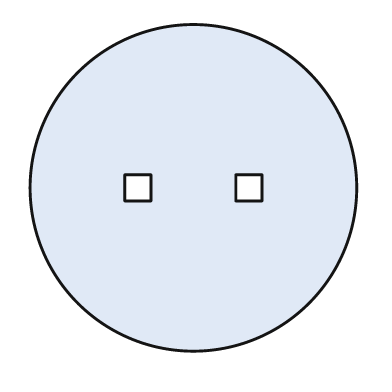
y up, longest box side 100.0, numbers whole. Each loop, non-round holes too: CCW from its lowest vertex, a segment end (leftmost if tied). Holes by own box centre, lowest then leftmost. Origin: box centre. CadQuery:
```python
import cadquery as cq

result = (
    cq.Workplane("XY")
    .moveTo(0.0, 0.0)
    .circle(50.0)
    .moveTo(-21.0, -4.0)
    .lineTo(-13.0, -4.0)
    .lineTo(-13.0, 4.0)
    .lineTo(-21.0, 4.0)
    .close()
    .moveTo(13.0, -4.0)
    .lineTo(21.0, -4.0)
    .lineTo(21.0, 4.0)
    .lineTo(13.0, 4.0)
    .close()
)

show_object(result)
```